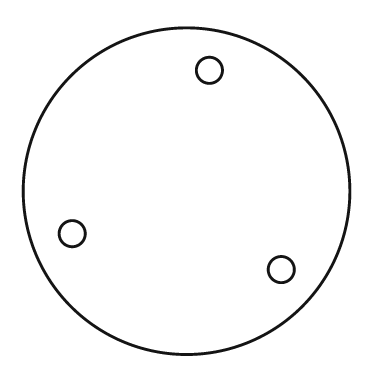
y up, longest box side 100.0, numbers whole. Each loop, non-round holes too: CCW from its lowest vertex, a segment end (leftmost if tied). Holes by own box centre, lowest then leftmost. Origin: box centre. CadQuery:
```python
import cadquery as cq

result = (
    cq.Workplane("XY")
    .moveTo(0.0, 0.0)
    .circle(50.0)
    .moveTo(29.0, -24.0)
    .circle(4.0)
    .moveTo(-35.0, -13.0)
    .circle(4.0)
    .moveTo(7.0, 37.0)
    .circle(4.0)
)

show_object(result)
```